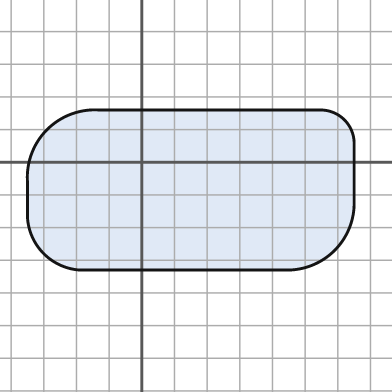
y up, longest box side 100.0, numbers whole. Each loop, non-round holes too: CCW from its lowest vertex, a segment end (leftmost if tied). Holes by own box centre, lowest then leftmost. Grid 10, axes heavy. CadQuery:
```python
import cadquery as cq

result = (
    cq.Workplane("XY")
    .moveTo(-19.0, -33.0)
    .lineTo(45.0, -33.0)
    .threePointArc((59.0, -27.0), (65.0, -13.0))
    .lineTo(65.0, 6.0)
    .threePointArc((62.0, 13.0), (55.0, 16.0))
    .lineTo(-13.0, 16.0)
    .threePointArc((-29.0, 10.0), (-35.0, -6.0))
    .lineTo(-35.0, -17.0)
    .threePointArc((-30.0, -28.0), (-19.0, -33.0))
    .close()
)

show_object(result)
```